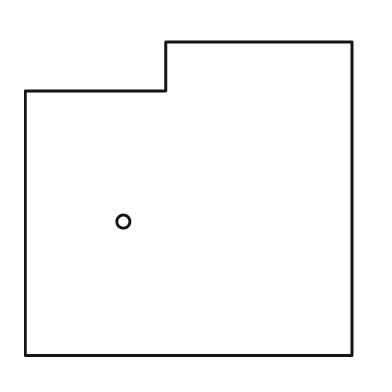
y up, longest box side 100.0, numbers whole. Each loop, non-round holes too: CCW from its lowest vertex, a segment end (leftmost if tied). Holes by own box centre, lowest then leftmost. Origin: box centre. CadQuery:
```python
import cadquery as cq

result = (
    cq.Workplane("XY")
    .moveTo(-50.0, -48.0)
    .lineTo(50.0, -48.0)
    .lineTo(50.0, 48.0)
    .lineTo(-7.0, 48.0)
    .lineTo(-7.0, 33.0)
    .lineTo(-50.0, 33.0)
    .close()
    .moveTo(-20.0, -7.0)
    .circle(2.0)
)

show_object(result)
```